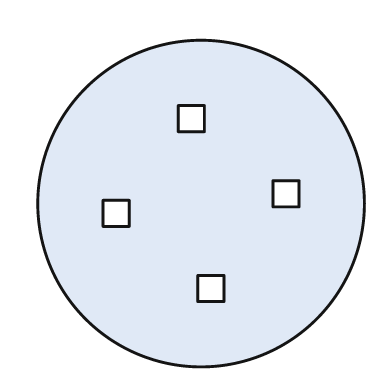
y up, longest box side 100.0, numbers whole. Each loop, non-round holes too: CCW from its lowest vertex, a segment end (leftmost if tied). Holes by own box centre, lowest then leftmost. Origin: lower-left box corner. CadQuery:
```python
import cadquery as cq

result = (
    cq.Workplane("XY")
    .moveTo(50.0, 50.0)
    .circle(50.0)
    .moveTo(49.0, 20.0)
    .lineTo(57.0, 20.0)
    .lineTo(57.0, 28.0)
    .lineTo(49.0, 28.0)
    .close()
    .moveTo(20.0, 43.0)
    .lineTo(28.0, 43.0)
    .lineTo(28.0, 51.0)
    .lineTo(20.0, 51.0)
    .close()
    .moveTo(72.0, 49.0)
    .lineTo(80.0, 49.0)
    .lineTo(80.0, 57.0)
    .lineTo(72.0, 57.0)
    .close()
    .moveTo(43.0, 72.0)
    .lineTo(51.0, 72.0)
    .lineTo(51.0, 80.0)
    .lineTo(43.0, 80.0)
    .close()
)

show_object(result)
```